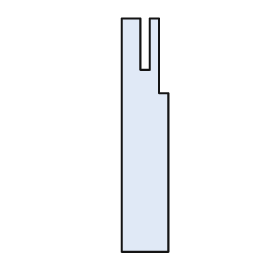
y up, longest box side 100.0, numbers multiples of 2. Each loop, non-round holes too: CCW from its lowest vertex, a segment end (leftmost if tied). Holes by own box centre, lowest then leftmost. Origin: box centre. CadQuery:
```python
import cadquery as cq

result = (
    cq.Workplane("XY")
    .moveTo(-10.0, -50.0)
    .lineTo(10.0, -50.0)
    .lineTo(10.0, 18.0)
    .lineTo(6.0, 18.0)
    .lineTo(6.0, 50.0)
    .lineTo(2.0, 50.0)
    .lineTo(2.0, 28.0)
    .lineTo(-2.0, 28.0)
    .lineTo(-2.0, 50.0)
    .lineTo(-10.0, 50.0)
    .close()
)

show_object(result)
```